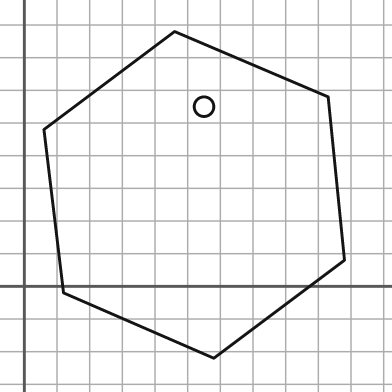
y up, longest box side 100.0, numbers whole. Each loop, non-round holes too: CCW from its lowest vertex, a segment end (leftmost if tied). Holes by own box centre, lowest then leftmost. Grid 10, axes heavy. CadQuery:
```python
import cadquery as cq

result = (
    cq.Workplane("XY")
    .moveTo(58.0, -22.0)
    .lineTo(98.0, 8.0)
    .lineTo(93.0, 58.0)
    .lineTo(46.0, 78.0)
    .lineTo(6.0, 48.0)
    .lineTo(12.0, -2.0)
    .close()
    .moveTo(55.0, 55.0)
    .circle(3.0)
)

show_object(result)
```